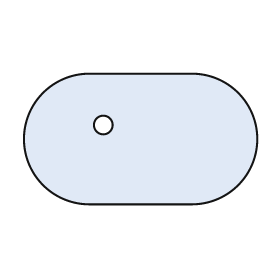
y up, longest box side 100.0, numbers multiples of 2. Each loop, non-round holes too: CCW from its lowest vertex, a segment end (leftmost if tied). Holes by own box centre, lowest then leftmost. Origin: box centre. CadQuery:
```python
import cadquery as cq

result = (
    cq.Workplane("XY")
    .moveTo(-22.0, -28.0)
    .lineTo(22.0, -28.0)
    .threePointArc((50.0, 0.0), (22.0, 28.0))
    .lineTo(-22.0, 28.0)
    .threePointArc((-50.0, 0.0), (-22.0, -28.0))
    .close()
    .moveTo(-16.0, 6.0)
    .circle(4.0)
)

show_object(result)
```